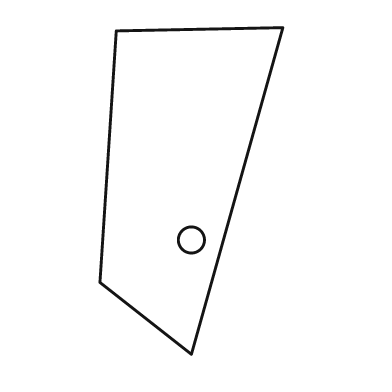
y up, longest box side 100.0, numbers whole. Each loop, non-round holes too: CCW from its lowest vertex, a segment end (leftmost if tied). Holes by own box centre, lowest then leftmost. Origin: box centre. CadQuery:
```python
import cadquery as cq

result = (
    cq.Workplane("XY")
    .moveTo(0.0, -50.0)
    .lineTo(28.0, 50.0)
    .lineTo(-23.0, 49.0)
    .lineTo(-28.0, -28.0)
    .close()
    .moveTo(0.0, -15.0)
    .circle(4.0)
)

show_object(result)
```